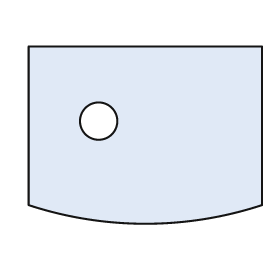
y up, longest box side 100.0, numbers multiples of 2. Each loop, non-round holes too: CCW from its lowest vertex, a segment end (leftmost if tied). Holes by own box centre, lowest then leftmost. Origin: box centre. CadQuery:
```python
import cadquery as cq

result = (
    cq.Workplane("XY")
    .moveTo(-50.0, -30.0)
    .threePointArc((0.0, -38.0), (50.0, -30.0))
    .lineTo(50.0, 38.0)
    .lineTo(-50.0, 38.0)
    .close()
    .moveTo(-20.0, 6.0)
    .circle(8.0)
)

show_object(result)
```